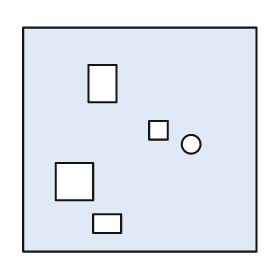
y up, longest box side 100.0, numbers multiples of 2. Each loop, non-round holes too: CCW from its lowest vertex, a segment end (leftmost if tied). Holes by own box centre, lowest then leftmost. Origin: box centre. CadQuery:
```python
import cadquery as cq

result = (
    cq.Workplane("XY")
    .moveTo(-50.0, -48.0)
    .lineTo(50.0, -48.0)
    .lineTo(50.0, 48.0)
    .lineTo(-50.0, 48.0)
    .close()
    .moveTo(-20.0, -40.0)
    .lineTo(-8.0, -40.0)
    .lineTo(-8.0, -32.0)
    .lineTo(-20.0, -32.0)
    .close()
    .moveTo(-36.0, -26.0)
    .lineTo(-20.0, -26.0)
    .lineTo(-20.0, -10.0)
    .lineTo(-36.0, -10.0)
    .close()
    .moveTo(22.0, -2.0)
    .circle(4.0)
    .moveTo(4.0, 0.0)
    .lineTo(12.0, 0.0)
    .lineTo(12.0, 8.0)
    .lineTo(4.0, 8.0)
    .close()
    .moveTo(-22.0, 16.0)
    .lineTo(-10.0, 16.0)
    .lineTo(-10.0, 32.0)
    .lineTo(-22.0, 32.0)
    .close()
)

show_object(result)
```